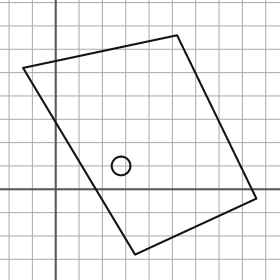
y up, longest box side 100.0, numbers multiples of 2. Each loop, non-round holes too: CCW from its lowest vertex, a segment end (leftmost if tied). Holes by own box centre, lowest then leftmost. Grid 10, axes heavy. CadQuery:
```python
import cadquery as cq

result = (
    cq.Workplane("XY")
    .moveTo(34.0, -28.0)
    .lineTo(86.0, -4.0)
    .lineTo(52.0, 66.0)
    .lineTo(-14.0, 52.0)
    .close()
    .moveTo(28.0, 10.0)
    .circle(4.0)
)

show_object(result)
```